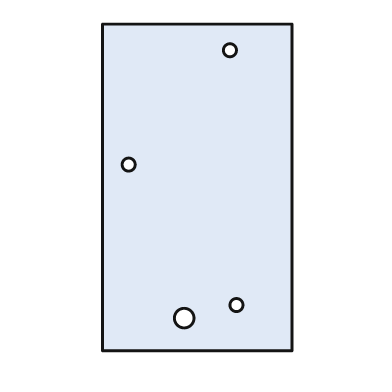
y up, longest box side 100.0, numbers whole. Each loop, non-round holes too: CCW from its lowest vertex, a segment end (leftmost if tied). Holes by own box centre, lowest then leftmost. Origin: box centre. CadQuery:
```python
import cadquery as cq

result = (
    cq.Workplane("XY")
    .moveTo(-29.0, -50.0)
    .lineTo(29.0, -50.0)
    .lineTo(29.0, 50.0)
    .lineTo(-29.0, 50.0)
    .close()
    .moveTo(-4.0, -40.0)
    .circle(3.0)
    .moveTo(12.0, -36.0)
    .circle(2.0)
    .moveTo(-21.0, 7.0)
    .circle(2.0)
    .moveTo(10.0, 42.0)
    .circle(2.0)
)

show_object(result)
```